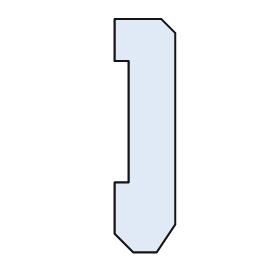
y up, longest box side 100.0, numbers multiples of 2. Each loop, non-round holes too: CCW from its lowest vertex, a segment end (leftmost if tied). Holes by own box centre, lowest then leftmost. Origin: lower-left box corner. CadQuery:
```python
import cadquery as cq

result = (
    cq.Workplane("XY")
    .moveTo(8.0, 0.0)
    .lineTo(18.0, 0.0)
    .lineTo(26.0, 12.0)
    .lineTo(26.0, 94.0)
    .lineTo(20.0, 100.0)
    .lineTo(0.0, 100.0)
    .lineTo(0.0, 82.0)
    .lineTo(6.0, 82.0)
    .lineTo(6.0, 30.0)
    .lineTo(0.0, 30.0)
    .lineTo(0.0, 8.0)
    .close()
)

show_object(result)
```